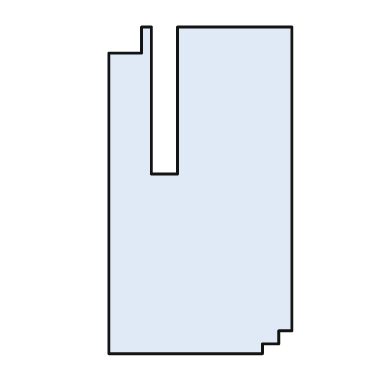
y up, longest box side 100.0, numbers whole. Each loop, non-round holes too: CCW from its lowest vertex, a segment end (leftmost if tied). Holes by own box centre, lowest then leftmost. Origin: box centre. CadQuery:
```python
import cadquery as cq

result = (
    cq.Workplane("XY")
    .moveTo(-28.0, -50.0)
    .lineTo(19.0, -50.0)
    .lineTo(19.0, -47.0)
    .lineTo(24.0, -47.0)
    .lineTo(24.0, -43.0)
    .lineTo(28.0, -43.0)
    .lineTo(28.0, 50.0)
    .lineTo(-7.0, 50.0)
    .lineTo(-7.0, 5.0)
    .lineTo(-15.0, 5.0)
    .lineTo(-15.0, 50.0)
    .lineTo(-18.0, 50.0)
    .lineTo(-18.0, 42.0)
    .lineTo(-28.0, 42.0)
    .close()
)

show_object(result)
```